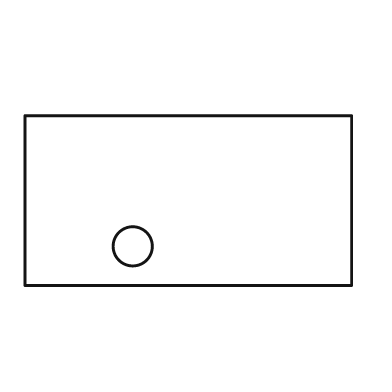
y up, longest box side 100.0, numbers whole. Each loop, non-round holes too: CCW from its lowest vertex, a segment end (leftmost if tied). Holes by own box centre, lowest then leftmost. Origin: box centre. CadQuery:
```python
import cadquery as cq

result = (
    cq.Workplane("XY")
    .moveTo(-50.0, -26.0)
    .lineTo(50.0, -26.0)
    .lineTo(50.0, 26.0)
    .lineTo(-50.0, 26.0)
    .close()
    .moveTo(-17.0, -14.0)
    .circle(6.0)
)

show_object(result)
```